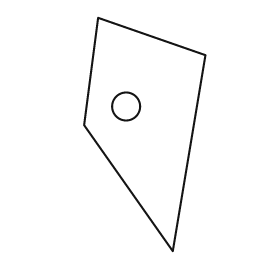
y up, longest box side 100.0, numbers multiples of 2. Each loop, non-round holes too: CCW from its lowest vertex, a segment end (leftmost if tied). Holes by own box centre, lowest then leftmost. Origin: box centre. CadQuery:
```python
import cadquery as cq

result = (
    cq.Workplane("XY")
    .moveTo(12.0, -50.0)
    .lineTo(26.0, 34.0)
    .lineTo(-20.0, 50.0)
    .lineTo(-26.0, 4.0)
    .close()
    .moveTo(-8.0, 12.0)
    .circle(6.0)
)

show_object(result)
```